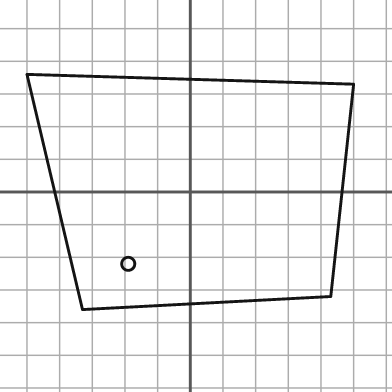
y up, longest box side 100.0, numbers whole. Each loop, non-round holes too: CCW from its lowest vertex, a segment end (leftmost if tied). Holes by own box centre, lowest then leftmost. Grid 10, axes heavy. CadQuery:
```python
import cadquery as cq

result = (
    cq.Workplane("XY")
    .moveTo(-33.0, -36.0)
    .lineTo(43.0, -32.0)
    .lineTo(50.0, 33.0)
    .lineTo(-50.0, 36.0)
    .close()
    .moveTo(-19.0, -22.0)
    .circle(2.0)
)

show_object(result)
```